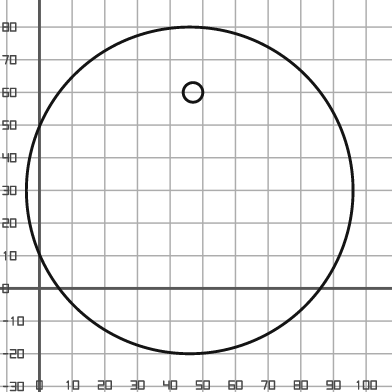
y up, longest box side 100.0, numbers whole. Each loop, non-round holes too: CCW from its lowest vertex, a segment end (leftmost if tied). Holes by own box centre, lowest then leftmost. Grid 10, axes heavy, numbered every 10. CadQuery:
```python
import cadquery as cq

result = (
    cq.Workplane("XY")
    .moveTo(46.0, 30.0)
    .circle(50.0)
    .moveTo(47.0, 60.0)
    .circle(3.0)
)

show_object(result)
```